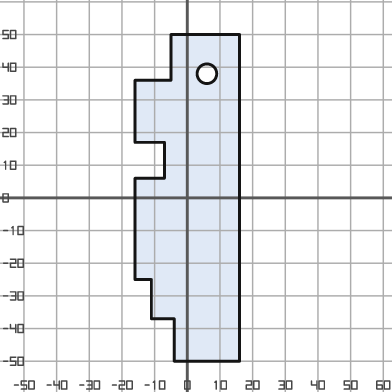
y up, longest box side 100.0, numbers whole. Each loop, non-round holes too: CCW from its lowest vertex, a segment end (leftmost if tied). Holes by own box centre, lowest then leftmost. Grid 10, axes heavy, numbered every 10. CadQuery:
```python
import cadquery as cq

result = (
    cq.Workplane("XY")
    .moveTo(-4.0, -50.0)
    .lineTo(16.0, -50.0)
    .lineTo(16.0, 50.0)
    .lineTo(-5.0, 50.0)
    .lineTo(-5.0, 36.0)
    .lineTo(-16.0, 36.0)
    .lineTo(-16.0, 17.0)
    .lineTo(-7.0, 17.0)
    .lineTo(-7.0, 6.0)
    .lineTo(-16.0, 6.0)
    .lineTo(-16.0, -25.0)
    .lineTo(-11.0, -25.0)
    .lineTo(-11.0, -37.0)
    .lineTo(-4.0, -37.0)
    .close()
    .moveTo(6.0, 38.0)
    .circle(3.0)
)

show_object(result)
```